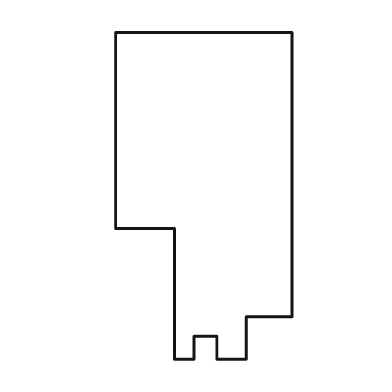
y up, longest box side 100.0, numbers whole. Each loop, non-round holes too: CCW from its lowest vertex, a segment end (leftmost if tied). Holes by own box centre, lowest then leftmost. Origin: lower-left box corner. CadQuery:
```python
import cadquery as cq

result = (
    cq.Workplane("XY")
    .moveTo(18.0, 0.0)
    .lineTo(24.0, 0.0)
    .lineTo(24.0, 7.0)
    .lineTo(31.0, 7.0)
    .lineTo(31.0, 0.0)
    .lineTo(40.0, 0.0)
    .lineTo(40.0, 13.0)
    .lineTo(54.0, 13.0)
    .lineTo(54.0, 100.0)
    .lineTo(0.0, 100.0)
    .lineTo(0.0, 40.0)
    .lineTo(18.0, 40.0)
    .close()
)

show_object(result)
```